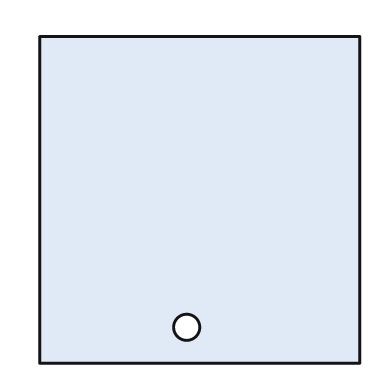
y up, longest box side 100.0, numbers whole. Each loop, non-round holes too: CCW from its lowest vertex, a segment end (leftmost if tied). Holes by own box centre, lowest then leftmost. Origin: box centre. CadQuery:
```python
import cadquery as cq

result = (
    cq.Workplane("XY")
    .moveTo(-49.0, -50.0)
    .lineTo(49.0, -50.0)
    .lineTo(49.0, 50.0)
    .lineTo(-49.0, 50.0)
    .close()
    .moveTo(-4.0, -39.0)
    .circle(4.0)
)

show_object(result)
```